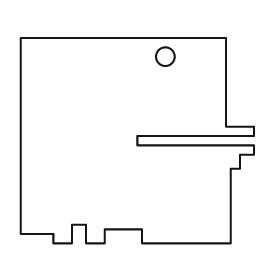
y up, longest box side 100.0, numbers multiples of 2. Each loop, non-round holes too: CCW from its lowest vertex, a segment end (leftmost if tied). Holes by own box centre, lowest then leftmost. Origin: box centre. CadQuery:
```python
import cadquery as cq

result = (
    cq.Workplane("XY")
    .moveTo(-36.0, -44.0)
    .lineTo(-28.0, -44.0)
    .lineTo(-28.0, -36.0)
    .lineTo(-22.0, -36.0)
    .lineTo(-22.0, -44.0)
    .lineTo(-14.0, -44.0)
    .lineTo(-14.0, -38.0)
    .lineTo(2.0, -38.0)
    .lineTo(2.0, -44.0)
    .lineTo(40.0, -44.0)
    .lineTo(40.0, -12.0)
    .lineTo(44.0, -12.0)
    .lineTo(44.0, -6.0)
    .lineTo(50.0, -6.0)
    .lineTo(50.0, -2.0)
    .lineTo(0.0, -2.0)
    .lineTo(0.0, 2.0)
    .lineTo(50.0, 2.0)
    .lineTo(50.0, 6.0)
    .lineTo(38.0, 6.0)
    .lineTo(38.0, 44.0)
    .lineTo(-50.0, 44.0)
    .lineTo(-50.0, -40.0)
    .lineTo(-36.0, -40.0)
    .close()
    .moveTo(12.0, 36.0)
    .circle(4.0)
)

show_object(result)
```